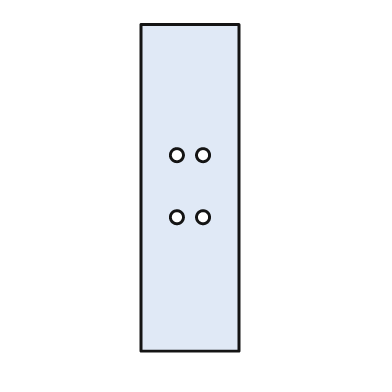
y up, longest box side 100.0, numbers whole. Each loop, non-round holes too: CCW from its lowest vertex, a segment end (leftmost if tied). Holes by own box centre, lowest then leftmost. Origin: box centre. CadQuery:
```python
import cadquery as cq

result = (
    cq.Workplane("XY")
    .moveTo(-15.0, -50.0)
    .lineTo(15.0, -50.0)
    .lineTo(15.0, 50.0)
    .lineTo(-15.0, 50.0)
    .close()
    .moveTo(-4.0, -9.0)
    .circle(2.0)
    .moveTo(4.0, -9.0)
    .circle(2.0)
    .moveTo(-4.0, 10.0)
    .circle(2.0)
    .moveTo(4.0, 10.0)
    .circle(2.0)
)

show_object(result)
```